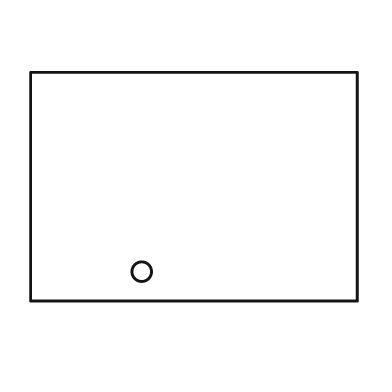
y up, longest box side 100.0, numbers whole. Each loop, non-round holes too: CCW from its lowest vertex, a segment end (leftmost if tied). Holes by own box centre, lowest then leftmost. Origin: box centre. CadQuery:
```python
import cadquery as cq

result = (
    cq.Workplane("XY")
    .moveTo(-50.0, -35.0)
    .lineTo(50.0, -35.0)
    .lineTo(50.0, 35.0)
    .lineTo(-50.0, 35.0)
    .close()
    .moveTo(-16.0, -26.0)
    .circle(3.0)
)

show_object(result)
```